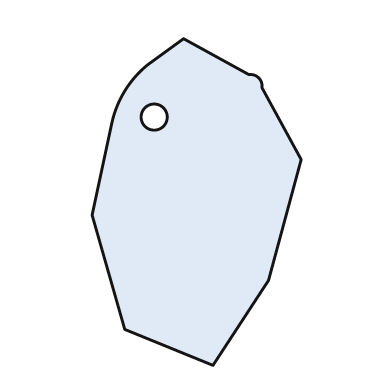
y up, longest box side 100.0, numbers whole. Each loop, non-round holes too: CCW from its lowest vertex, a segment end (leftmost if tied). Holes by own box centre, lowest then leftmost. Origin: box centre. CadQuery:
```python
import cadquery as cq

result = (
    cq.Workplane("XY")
    .moveTo(5.0, -50.0)
    .lineTo(22.0, -24.0)
    .lineTo(32.0, 13.0)
    .lineTo(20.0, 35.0)
    .threePointArc((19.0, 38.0), (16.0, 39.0))
    .lineTo(-4.0, 50.0)
    .lineTo(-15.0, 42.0)
    .threePointArc((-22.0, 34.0), (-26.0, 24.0))
    .lineTo(-32.0, -4.0)
    .lineTo(-22.0, -39.0)
    .close()
    .moveTo(-13.0, 26.0)
    .circle(4.0)
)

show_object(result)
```